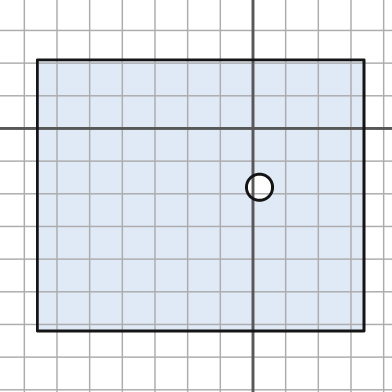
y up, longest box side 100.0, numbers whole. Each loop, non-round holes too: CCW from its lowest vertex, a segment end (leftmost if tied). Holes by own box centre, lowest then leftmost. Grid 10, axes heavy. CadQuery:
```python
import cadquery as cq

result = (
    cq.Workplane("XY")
    .moveTo(-66.0, -62.0)
    .lineTo(34.0, -62.0)
    .lineTo(34.0, 21.0)
    .lineTo(-66.0, 21.0)
    .close()
    .moveTo(2.0, -18.0)
    .circle(4.0)
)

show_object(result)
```